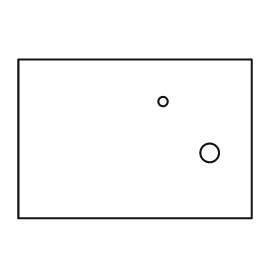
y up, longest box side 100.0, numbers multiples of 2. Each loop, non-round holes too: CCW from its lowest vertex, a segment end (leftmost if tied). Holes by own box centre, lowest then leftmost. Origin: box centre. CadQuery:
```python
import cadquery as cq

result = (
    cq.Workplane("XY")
    .moveTo(-50.0, -34.0)
    .lineTo(50.0, -34.0)
    .lineTo(50.0, 34.0)
    .lineTo(-50.0, 34.0)
    .close()
    .moveTo(32.0, -6.0)
    .circle(4.0)
    .moveTo(12.0, 16.0)
    .circle(2.0)
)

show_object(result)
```